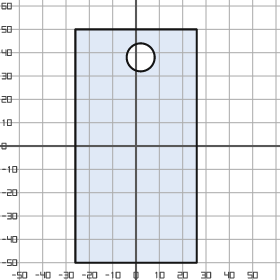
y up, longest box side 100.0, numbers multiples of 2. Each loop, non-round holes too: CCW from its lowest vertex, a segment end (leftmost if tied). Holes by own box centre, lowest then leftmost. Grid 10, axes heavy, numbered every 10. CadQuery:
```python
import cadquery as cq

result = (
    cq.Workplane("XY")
    .moveTo(-26.0, -50.0)
    .lineTo(26.0, -50.0)
    .lineTo(26.0, 50.0)
    .lineTo(-26.0, 50.0)
    .close()
    .moveTo(2.0, 38.0)
    .circle(6.0)
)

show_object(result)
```